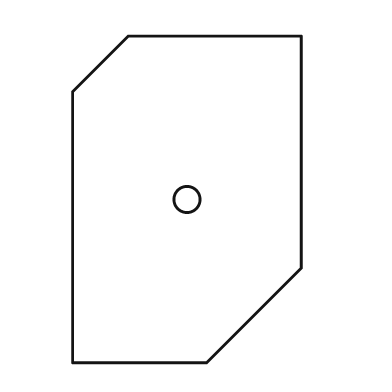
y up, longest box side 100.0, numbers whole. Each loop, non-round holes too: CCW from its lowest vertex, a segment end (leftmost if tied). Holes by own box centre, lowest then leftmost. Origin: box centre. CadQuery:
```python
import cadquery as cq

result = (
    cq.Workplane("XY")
    .moveTo(-35.0, -50.0)
    .lineTo(6.0, -50.0)
    .lineTo(35.0, -21.0)
    .lineTo(35.0, 50.0)
    .lineTo(-18.0, 50.0)
    .lineTo(-35.0, 33.0)
    .close()
    .moveTo(0.0, 0.0)
    .circle(4.0)
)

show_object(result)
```